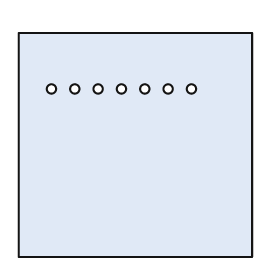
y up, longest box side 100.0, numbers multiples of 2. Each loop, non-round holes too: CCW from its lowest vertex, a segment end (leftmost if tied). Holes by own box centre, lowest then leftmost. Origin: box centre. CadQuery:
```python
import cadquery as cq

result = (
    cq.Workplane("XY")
    .moveTo(-50.0, -48.0)
    .lineTo(50.0, -48.0)
    .lineTo(50.0, 48.0)
    .lineTo(-50.0, 48.0)
    .close()
    .moveTo(-36.0, 24.0)
    .circle(2.0)
    .moveTo(-26.0, 24.0)
    .circle(2.0)
    .moveTo(-16.0, 24.0)
    .circle(2.0)
    .moveTo(-6.0, 24.0)
    .circle(2.0)
    .moveTo(4.0, 24.0)
    .circle(2.0)
    .moveTo(14.0, 24.0)
    .circle(2.0)
    .moveTo(24.0, 24.0)
    .circle(2.0)
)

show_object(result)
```